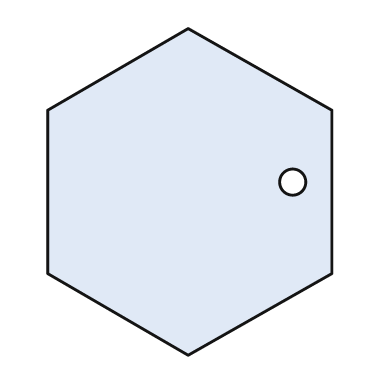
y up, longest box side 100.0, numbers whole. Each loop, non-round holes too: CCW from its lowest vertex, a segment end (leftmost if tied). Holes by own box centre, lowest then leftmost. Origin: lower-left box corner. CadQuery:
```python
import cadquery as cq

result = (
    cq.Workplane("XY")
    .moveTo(43.0, 0.0)
    .lineTo(87.0, 25.0)
    .lineTo(87.0, 75.0)
    .lineTo(43.0, 100.0)
    .lineTo(0.0, 75.0)
    .lineTo(0.0, 25.0)
    .close()
    .moveTo(75.0, 53.0)
    .circle(4.0)
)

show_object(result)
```